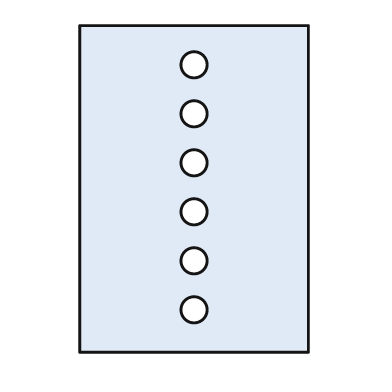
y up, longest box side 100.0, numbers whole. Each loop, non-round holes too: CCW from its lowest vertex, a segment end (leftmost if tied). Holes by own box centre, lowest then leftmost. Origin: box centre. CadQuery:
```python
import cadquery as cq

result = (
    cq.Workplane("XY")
    .moveTo(-35.0, -50.0)
    .lineTo(35.0, -50.0)
    .lineTo(35.0, 50.0)
    .lineTo(-35.0, 50.0)
    .close()
    .moveTo(0.0, -37.0)
    .circle(4.0)
    .moveTo(0.0, -22.0)
    .circle(4.0)
    .moveTo(0.0, -7.0)
    .circle(4.0)
    .moveTo(0.0, 8.0)
    .circle(4.0)
    .moveTo(0.0, 23.0)
    .circle(4.0)
    .moveTo(0.0, 38.0)
    .circle(4.0)
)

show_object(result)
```